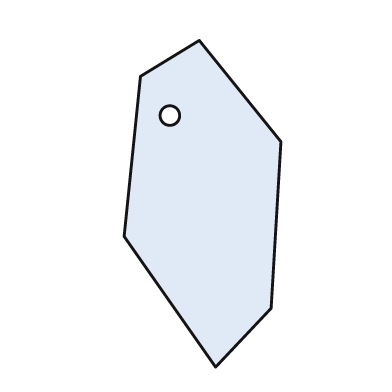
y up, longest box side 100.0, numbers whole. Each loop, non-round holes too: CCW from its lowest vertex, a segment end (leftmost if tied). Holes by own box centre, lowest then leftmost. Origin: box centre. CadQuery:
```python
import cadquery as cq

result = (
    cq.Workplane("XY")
    .moveTo(4.0, -50.0)
    .lineTo(21.0, -32.0)
    .lineTo(24.0, 19.0)
    .lineTo(-1.0, 50.0)
    .lineTo(-19.0, 39.0)
    .lineTo(-24.0, -10.0)
    .close()
    .moveTo(-10.0, 27.0)
    .circle(3.0)
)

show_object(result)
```